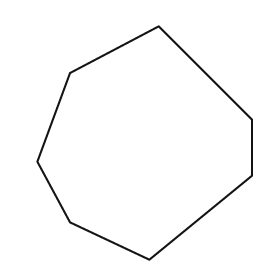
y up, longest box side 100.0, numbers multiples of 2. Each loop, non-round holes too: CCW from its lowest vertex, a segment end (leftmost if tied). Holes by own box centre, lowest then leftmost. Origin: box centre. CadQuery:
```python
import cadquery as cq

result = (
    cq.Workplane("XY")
    .moveTo(2.0, -50.0)
    .lineTo(46.0, -14.0)
    .lineTo(46.0, 10.0)
    .lineTo(6.0, 50.0)
    .lineTo(-32.0, 30.0)
    .lineTo(-46.0, -8.0)
    .lineTo(-32.0, -34.0)
    .close()
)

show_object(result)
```